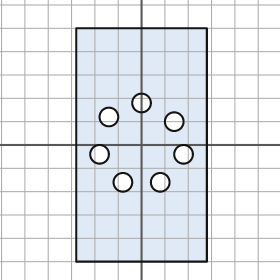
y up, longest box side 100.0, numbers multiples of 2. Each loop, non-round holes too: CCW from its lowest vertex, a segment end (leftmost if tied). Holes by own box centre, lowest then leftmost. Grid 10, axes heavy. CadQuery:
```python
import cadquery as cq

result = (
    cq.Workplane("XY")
    .moveTo(-28.0, -50.0)
    .lineTo(28.0, -50.0)
    .lineTo(28.0, 50.0)
    .lineTo(-28.0, 50.0)
    .close()
    .moveTo(-8.0, -16.0)
    .circle(4.0)
    .moveTo(8.0, -16.0)
    .circle(4.0)
    .moveTo(-18.0, -4.0)
    .circle(4.0)
    .moveTo(18.0, -4.0)
    .circle(4.0)
    .moveTo(14.0, 10.0)
    .circle(4.0)
    .moveTo(-14.0, 12.0)
    .circle(4.0)
    .moveTo(0.0, 18.0)
    .circle(4.0)
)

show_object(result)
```